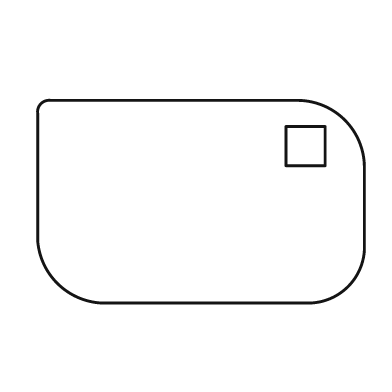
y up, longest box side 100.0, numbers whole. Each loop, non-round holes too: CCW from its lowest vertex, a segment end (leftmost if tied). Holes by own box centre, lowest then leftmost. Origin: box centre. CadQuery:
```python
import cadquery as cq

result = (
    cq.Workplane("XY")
    .moveTo(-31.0, -31.0)
    .lineTo(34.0, -31.0)
    .threePointArc((45.0, -26.0), (50.0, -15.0))
    .lineTo(50.0, 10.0)
    .threePointArc((44.0, 25.0), (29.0, 31.0))
    .lineTo(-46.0, 31.0)
    .threePointArc((-49.0, 30.0), (-50.0, 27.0))
    .lineTo(-50.0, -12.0)
    .threePointArc((-44.0, -25.0), (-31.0, -31.0))
    .close()
    .moveTo(26.0, 11.0)
    .lineTo(38.0, 11.0)
    .lineTo(38.0, 23.0)
    .lineTo(26.0, 23.0)
    .close()
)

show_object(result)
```